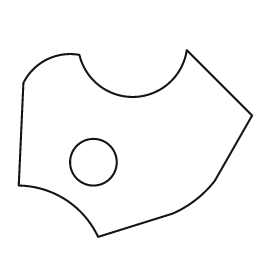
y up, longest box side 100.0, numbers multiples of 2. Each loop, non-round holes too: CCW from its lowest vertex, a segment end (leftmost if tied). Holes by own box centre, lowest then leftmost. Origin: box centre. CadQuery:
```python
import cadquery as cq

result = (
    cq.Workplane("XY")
    .moveTo(-16.0, -40.0)
    .lineTo(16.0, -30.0)
    .threePointArc((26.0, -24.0), (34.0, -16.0))
    .lineTo(50.0, 12.0)
    .lineTo(22.0, 40.0)
    .threePointArc((0.0, 20.0), (-24.0, 38.0))
    .threePointArc((-38.0, 36.0), (-48.0, 26.0))
    .lineTo(-50.0, -18.0)
    .threePointArc((-30.0, -24.0), (-16.0, -40.0))
    .close()
    .moveTo(-18.0, -8.0)
    .circle(10.0)
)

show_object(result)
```